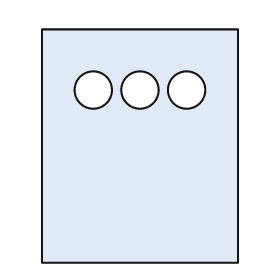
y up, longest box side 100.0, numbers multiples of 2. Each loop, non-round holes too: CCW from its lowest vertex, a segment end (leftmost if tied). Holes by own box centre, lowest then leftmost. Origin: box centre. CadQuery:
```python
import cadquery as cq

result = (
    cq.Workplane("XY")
    .moveTo(-42.0, -50.0)
    .lineTo(42.0, -50.0)
    .lineTo(42.0, 50.0)
    .lineTo(-42.0, 50.0)
    .close()
    .moveTo(-20.0, 24.0)
    .circle(8.0)
    .moveTo(0.0, 24.0)
    .circle(8.0)
    .moveTo(20.0, 24.0)
    .circle(8.0)
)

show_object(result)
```